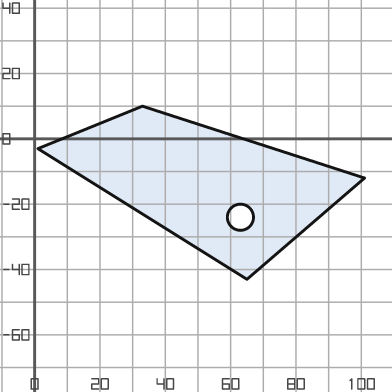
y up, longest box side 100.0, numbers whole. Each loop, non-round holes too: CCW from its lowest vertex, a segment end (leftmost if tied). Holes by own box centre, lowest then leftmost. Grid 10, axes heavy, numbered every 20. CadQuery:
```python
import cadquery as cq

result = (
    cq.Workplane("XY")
    .moveTo(65.0, -43.0)
    .lineTo(101.0, -12.0)
    .lineTo(33.0, 10.0)
    .lineTo(1.0, -3.0)
    .close()
    .moveTo(63.0, -24.0)
    .circle(4.0)
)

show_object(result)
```